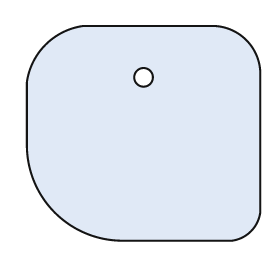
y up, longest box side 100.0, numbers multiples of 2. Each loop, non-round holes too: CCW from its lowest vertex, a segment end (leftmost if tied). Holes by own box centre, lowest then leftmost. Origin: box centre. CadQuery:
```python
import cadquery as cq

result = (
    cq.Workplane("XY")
    .moveTo(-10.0, -46.0)
    .lineTo(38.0, -46.0)
    .threePointArc((46.0, -42.0), (50.0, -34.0))
    .lineTo(50.0, 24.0)
    .threePointArc((44.0, 40.0), (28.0, 46.0))
    .lineTo(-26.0, 46.0)
    .threePointArc((-42.0, 38.0), (-50.0, 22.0))
    .lineTo(-50.0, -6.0)
    .threePointArc((-38.0, -34.0), (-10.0, -46.0))
    .close()
    .moveTo(0.0, 24.0)
    .circle(4.0)
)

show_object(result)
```